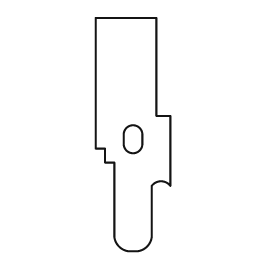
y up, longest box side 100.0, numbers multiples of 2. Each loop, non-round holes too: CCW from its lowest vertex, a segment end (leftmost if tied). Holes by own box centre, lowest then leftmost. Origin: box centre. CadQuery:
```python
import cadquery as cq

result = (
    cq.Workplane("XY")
    .moveTo(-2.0, -50.0)
    .lineTo(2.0, -50.0)
    .threePointArc((6.0, -48.0), (8.0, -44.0))
    .lineTo(8.0, -22.0)
    .threePointArc((12.0, -20.0), (16.0, -22.0))
    .lineTo(16.0, 8.0)
    .lineTo(10.0, 8.0)
    .lineTo(10.0, 50.0)
    .lineTo(-16.0, 50.0)
    .lineTo(-16.0, -6.0)
    .lineTo(-12.0, -6.0)
    .lineTo(-12.0, -12.0)
    .lineTo(-8.0, -12.0)
    .lineTo(-8.0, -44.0)
    .threePointArc((-6.0, -48.0), (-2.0, -50.0))
    .close()
    .moveTo(-4.0, -4.0)
    .threePointArc((0.0, -8.0), (4.0, -4.0))
    .lineTo(4.0, 0.0)
    .threePointArc((0.0, 4.0), (-4.0, 0.0))
    .close()
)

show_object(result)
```